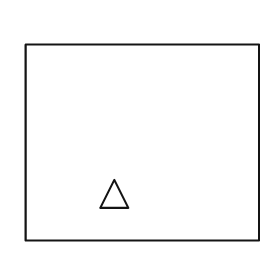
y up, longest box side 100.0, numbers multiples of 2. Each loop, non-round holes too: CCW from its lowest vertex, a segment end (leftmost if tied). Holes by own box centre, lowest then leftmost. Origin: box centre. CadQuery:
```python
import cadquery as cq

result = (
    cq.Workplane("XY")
    .moveTo(-50.0, -42.0)
    .lineTo(50.0, -42.0)
    .lineTo(50.0, 42.0)
    .lineTo(-50.0, 42.0)
    .close()
    .moveTo(-18.0, -28.0)
    .lineTo(-6.0, -28.0)
    .lineTo(-12.0, -16.0)
    .close()
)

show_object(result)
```